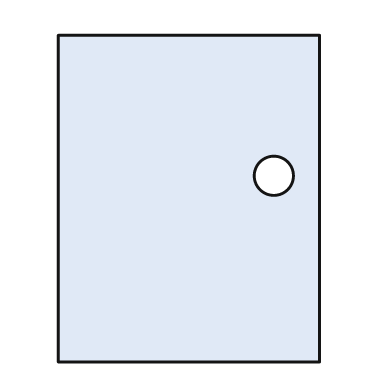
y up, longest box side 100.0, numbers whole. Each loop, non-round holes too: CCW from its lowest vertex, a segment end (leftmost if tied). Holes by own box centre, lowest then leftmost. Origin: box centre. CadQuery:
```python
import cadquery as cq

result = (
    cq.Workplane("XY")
    .moveTo(-40.0, -50.0)
    .lineTo(40.0, -50.0)
    .lineTo(40.0, 50.0)
    .lineTo(-40.0, 50.0)
    .close()
    .moveTo(26.0, 7.0)
    .circle(6.0)
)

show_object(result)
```